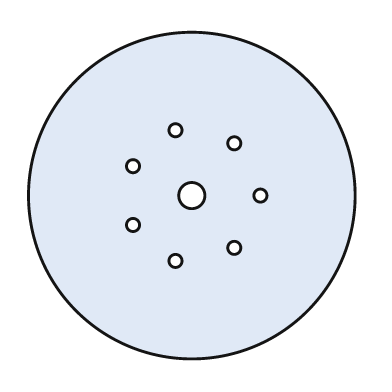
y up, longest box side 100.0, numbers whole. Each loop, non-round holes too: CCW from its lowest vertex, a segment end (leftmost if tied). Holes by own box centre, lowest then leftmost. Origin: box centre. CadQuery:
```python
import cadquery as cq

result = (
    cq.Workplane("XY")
    .moveTo(0.0, 0.0)
    .circle(50.0)
    .moveTo(-5.0, -20.0)
    .circle(2.0)
    .moveTo(13.0, -16.0)
    .circle(2.0)
    .moveTo(-18.0, -9.0)
    .circle(2.0)
    .moveTo(0.0, 0.0)
    .circle(4.0)
    .moveTo(21.0, 0.0)
    .circle(2.0)
    .moveTo(-18.0, 9.0)
    .circle(2.0)
    .moveTo(13.0, 16.0)
    .circle(2.0)
    .moveTo(-5.0, 20.0)
    .circle(2.0)
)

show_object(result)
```